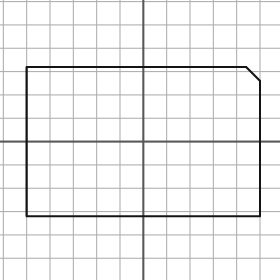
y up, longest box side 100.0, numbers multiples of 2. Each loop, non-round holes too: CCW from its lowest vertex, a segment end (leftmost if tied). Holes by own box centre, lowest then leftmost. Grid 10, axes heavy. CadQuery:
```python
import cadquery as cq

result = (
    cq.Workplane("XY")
    .moveTo(-50.0, -32.0)
    .lineTo(50.0, -32.0)
    .lineTo(50.0, 26.0)
    .lineTo(44.0, 32.0)
    .lineTo(-50.0, 32.0)
    .close()
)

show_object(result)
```